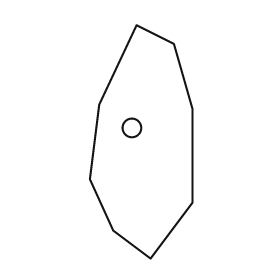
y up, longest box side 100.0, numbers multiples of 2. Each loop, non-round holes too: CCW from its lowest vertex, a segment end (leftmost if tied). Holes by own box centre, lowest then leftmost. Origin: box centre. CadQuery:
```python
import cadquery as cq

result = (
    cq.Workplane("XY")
    .moveTo(4.0, -50.0)
    .lineTo(22.0, -26.0)
    .lineTo(22.0, 14.0)
    .lineTo(14.0, 42.0)
    .lineTo(-2.0, 50.0)
    .lineTo(-18.0, 16.0)
    .lineTo(-22.0, -16.0)
    .lineTo(-12.0, -38.0)
    .close()
    .moveTo(-4.0, 6.0)
    .circle(4.0)
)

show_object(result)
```